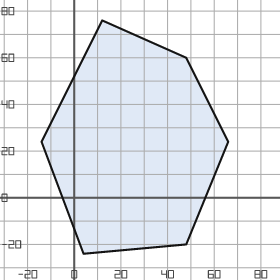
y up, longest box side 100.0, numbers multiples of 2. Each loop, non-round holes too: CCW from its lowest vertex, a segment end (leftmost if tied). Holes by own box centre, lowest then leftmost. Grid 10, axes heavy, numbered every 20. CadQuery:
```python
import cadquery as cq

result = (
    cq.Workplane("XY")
    .moveTo(4.0, -24.0)
    .lineTo(48.0, -20.0)
    .lineTo(66.0, 24.0)
    .lineTo(48.0, 60.0)
    .lineTo(12.0, 76.0)
    .lineTo(-14.0, 24.0)
    .close()
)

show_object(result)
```